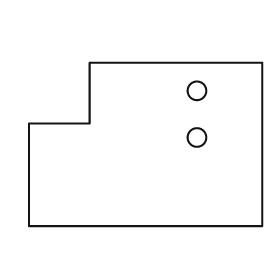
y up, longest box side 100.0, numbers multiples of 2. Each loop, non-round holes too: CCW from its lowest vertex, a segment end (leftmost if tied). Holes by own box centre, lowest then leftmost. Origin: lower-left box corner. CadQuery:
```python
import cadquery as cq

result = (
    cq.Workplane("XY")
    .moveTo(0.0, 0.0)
    .lineTo(100.0, 0.0)
    .lineTo(100.0, 70.0)
    .lineTo(26.0, 70.0)
    .lineTo(26.0, 44.0)
    .lineTo(0.0, 44.0)
    .close()
    .moveTo(72.0, 38.0)
    .circle(4.0)
    .moveTo(72.0, 58.0)
    .circle(4.0)
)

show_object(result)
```